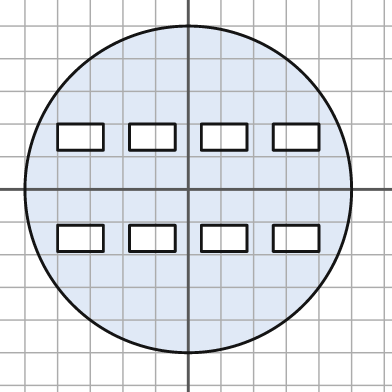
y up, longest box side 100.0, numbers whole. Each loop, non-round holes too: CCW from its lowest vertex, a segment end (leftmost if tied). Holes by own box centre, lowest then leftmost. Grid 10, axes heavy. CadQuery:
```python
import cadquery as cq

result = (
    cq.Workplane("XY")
    .moveTo(0.0, 0.0)
    .circle(50.0)
    .moveTo(-40.0, -19.0)
    .lineTo(-26.0, -19.0)
    .lineTo(-26.0, -11.0)
    .lineTo(-40.0, -11.0)
    .close()
    .moveTo(-18.0, -19.0)
    .lineTo(-4.0, -19.0)
    .lineTo(-4.0, -11.0)
    .lineTo(-18.0, -11.0)
    .close()
    .moveTo(4.0, -19.0)
    .lineTo(18.0, -19.0)
    .lineTo(18.0, -11.0)
    .lineTo(4.0, -11.0)
    .close()
    .moveTo(26.0, -19.0)
    .lineTo(40.0, -19.0)
    .lineTo(40.0, -11.0)
    .lineTo(26.0, -11.0)
    .close()
    .moveTo(-40.0, 12.0)
    .lineTo(-26.0, 12.0)
    .lineTo(-26.0, 20.0)
    .lineTo(-40.0, 20.0)
    .close()
    .moveTo(-18.0, 12.0)
    .lineTo(-4.0, 12.0)
    .lineTo(-4.0, 20.0)
    .lineTo(-18.0, 20.0)
    .close()
    .moveTo(4.0, 12.0)
    .lineTo(18.0, 12.0)
    .lineTo(18.0, 20.0)
    .lineTo(4.0, 20.0)
    .close()
    .moveTo(26.0, 12.0)
    .lineTo(40.0, 12.0)
    .lineTo(40.0, 20.0)
    .lineTo(26.0, 20.0)
    .close()
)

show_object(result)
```